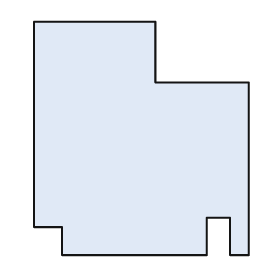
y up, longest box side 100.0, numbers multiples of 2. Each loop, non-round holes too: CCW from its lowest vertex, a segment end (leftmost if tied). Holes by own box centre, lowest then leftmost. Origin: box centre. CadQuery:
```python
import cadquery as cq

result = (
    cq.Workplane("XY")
    .moveTo(-34.0, -50.0)
    .lineTo(28.0, -50.0)
    .lineTo(28.0, -34.0)
    .lineTo(38.0, -34.0)
    .lineTo(38.0, -50.0)
    .lineTo(46.0, -50.0)
    .lineTo(46.0, 24.0)
    .lineTo(6.0, 24.0)
    .lineTo(6.0, 50.0)
    .lineTo(-46.0, 50.0)
    .lineTo(-46.0, -38.0)
    .lineTo(-34.0, -38.0)
    .close()
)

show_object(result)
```